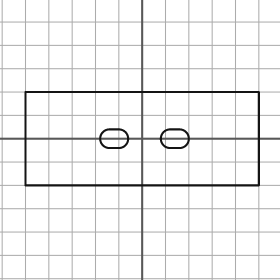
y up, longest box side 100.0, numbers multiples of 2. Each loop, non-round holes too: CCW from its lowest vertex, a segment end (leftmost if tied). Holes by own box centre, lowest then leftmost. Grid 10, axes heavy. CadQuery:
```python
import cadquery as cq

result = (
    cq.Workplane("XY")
    .moveTo(-50.0, -20.0)
    .lineTo(50.0, -20.0)
    .lineTo(50.0, 20.0)
    .lineTo(-50.0, 20.0)
    .close()
    .moveTo(-14.0, -4.0)
    .lineTo(-10.0, -4.0)
    .threePointArc((-6.0, 0.0), (-10.0, 4.0))
    .lineTo(-14.0, 4.0)
    .threePointArc((-18.0, 0.0), (-14.0, -4.0))
    .close()
    .moveTo(12.0, -4.0)
    .lineTo(16.0, -4.0)
    .threePointArc((20.0, 0.0), (16.0, 4.0))
    .lineTo(12.0, 4.0)
    .threePointArc((8.0, 0.0), (12.0, -4.0))
    .close()
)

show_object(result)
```